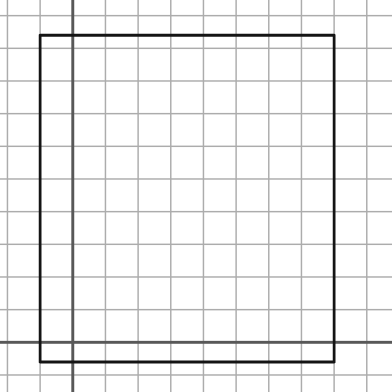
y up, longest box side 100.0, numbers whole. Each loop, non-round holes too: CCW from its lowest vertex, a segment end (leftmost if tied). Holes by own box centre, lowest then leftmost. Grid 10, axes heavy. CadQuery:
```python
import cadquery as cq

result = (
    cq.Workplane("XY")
    .moveTo(-10.0, -6.0)
    .lineTo(80.0, -6.0)
    .lineTo(80.0, 94.0)
    .lineTo(-10.0, 94.0)
    .close()
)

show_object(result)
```